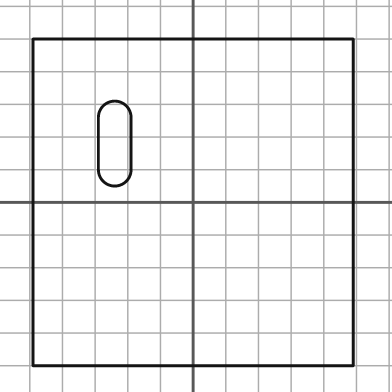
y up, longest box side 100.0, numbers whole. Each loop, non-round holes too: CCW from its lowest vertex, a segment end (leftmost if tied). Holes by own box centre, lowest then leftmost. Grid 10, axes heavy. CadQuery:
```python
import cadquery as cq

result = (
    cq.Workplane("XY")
    .moveTo(-49.0, -50.0)
    .lineTo(49.0, -50.0)
    .lineTo(49.0, 50.0)
    .lineTo(-49.0, 50.0)
    .close()
    .moveTo(-29.0, 10.0)
    .threePointArc((-24.0, 5.0), (-19.0, 10.0))
    .lineTo(-19.0, 26.0)
    .threePointArc((-24.0, 31.0), (-29.0, 26.0))
    .close()
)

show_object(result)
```